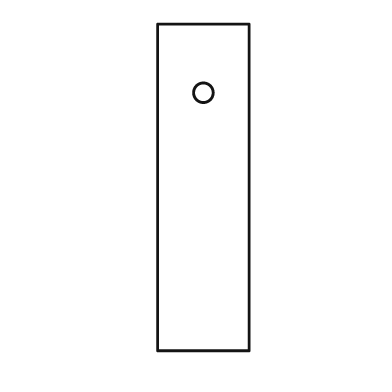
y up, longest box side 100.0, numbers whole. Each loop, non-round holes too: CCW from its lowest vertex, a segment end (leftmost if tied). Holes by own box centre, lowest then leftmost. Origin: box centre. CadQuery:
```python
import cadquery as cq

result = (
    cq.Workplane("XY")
    .moveTo(-14.0, -50.0)
    .lineTo(14.0, -50.0)
    .lineTo(14.0, 50.0)
    .lineTo(-14.0, 50.0)
    .close()
    .moveTo(0.0, 29.0)
    .circle(3.0)
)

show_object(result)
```